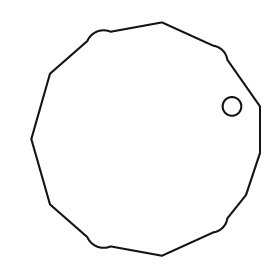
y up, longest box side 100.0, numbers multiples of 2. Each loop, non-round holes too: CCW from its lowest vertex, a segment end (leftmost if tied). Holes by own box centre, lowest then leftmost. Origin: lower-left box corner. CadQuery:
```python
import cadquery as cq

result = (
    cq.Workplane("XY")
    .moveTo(56.0, 0.0)
    .lineTo(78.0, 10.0)
    .threePointArc((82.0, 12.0), (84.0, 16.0))
    .lineTo(92.0, 26.0)
    .lineTo(98.0, 44.0)
    .lineTo(98.0, 64.0)
    .lineTo(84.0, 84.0)
    .threePointArc((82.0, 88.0), (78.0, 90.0))
    .lineTo(56.0, 100.0)
    .lineTo(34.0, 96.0)
    .threePointArc((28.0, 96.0), (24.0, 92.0))
    .lineTo(8.0, 78.0)
    .lineTo(0.0, 50.0)
    .lineTo(8.0, 22.0)
    .lineTo(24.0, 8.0)
    .threePointArc((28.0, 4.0), (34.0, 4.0))
    .close()
    .moveTo(86.0, 64.0)
    .circle(4.0)
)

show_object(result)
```